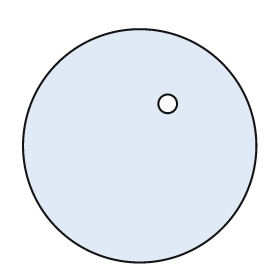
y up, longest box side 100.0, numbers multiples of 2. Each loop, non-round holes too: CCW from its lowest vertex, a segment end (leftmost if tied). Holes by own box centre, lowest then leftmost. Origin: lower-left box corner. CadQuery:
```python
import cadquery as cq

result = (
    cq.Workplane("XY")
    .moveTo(50.0, 50.0)
    .circle(50.0)
    .moveTo(62.0, 68.0)
    .circle(4.0)
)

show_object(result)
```